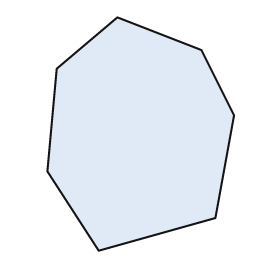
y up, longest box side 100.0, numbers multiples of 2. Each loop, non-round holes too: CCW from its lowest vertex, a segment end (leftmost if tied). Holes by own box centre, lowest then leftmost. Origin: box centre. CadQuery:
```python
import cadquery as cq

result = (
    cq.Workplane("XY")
    .moveTo(-18.0, -50.0)
    .lineTo(32.0, -36.0)
    .lineTo(40.0, 8.0)
    .lineTo(26.0, 36.0)
    .lineTo(-10.0, 50.0)
    .lineTo(-36.0, 28.0)
    .lineTo(-40.0, -16.0)
    .close()
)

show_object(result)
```